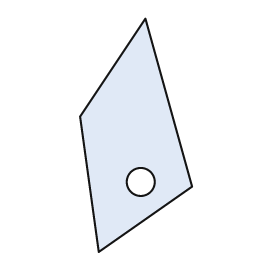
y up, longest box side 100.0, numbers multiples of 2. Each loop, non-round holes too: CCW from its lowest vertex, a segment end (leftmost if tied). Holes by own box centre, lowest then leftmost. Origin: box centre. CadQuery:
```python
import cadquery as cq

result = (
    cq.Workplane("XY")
    .moveTo(-16.0, -50.0)
    .lineTo(24.0, -22.0)
    .lineTo(4.0, 50.0)
    .lineTo(-24.0, 8.0)
    .close()
    .moveTo(2.0, -20.0)
    .circle(6.0)
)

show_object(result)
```